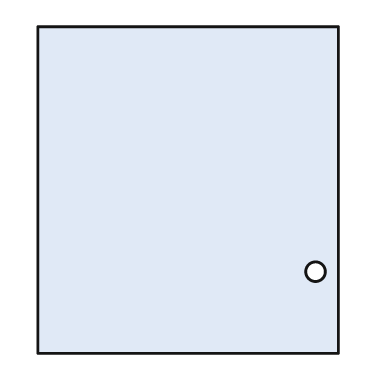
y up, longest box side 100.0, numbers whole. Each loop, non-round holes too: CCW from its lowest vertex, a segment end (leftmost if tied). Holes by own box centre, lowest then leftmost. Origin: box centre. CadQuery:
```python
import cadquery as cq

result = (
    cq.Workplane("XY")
    .moveTo(-46.0, -50.0)
    .lineTo(46.0, -50.0)
    .lineTo(46.0, 50.0)
    .lineTo(-46.0, 50.0)
    .close()
    .moveTo(39.0, -25.0)
    .circle(3.0)
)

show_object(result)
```